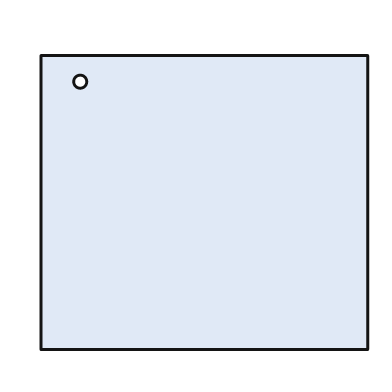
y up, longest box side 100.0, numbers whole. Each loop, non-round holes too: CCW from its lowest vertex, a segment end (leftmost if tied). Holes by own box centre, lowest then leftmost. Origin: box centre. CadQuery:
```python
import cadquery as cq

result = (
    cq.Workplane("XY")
    .moveTo(-50.0, -45.0)
    .lineTo(50.0, -45.0)
    .lineTo(50.0, 45.0)
    .lineTo(-50.0, 45.0)
    .close()
    .moveTo(-38.0, 37.0)
    .circle(2.0)
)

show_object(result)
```